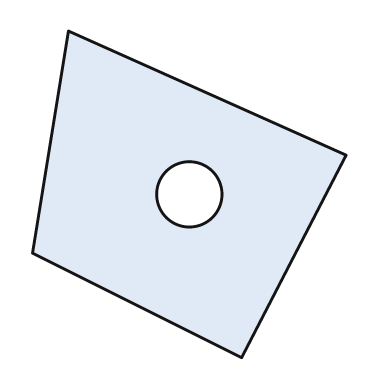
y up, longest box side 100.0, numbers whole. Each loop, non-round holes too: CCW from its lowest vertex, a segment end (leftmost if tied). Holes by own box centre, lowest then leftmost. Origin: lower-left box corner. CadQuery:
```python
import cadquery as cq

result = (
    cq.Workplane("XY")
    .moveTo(64.0, 0.0)
    .lineTo(96.0, 62.0)
    .lineTo(11.0, 100.0)
    .lineTo(0.0, 32.0)
    .close()
    .moveTo(48.0, 50.0)
    .circle(10.0)
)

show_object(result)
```